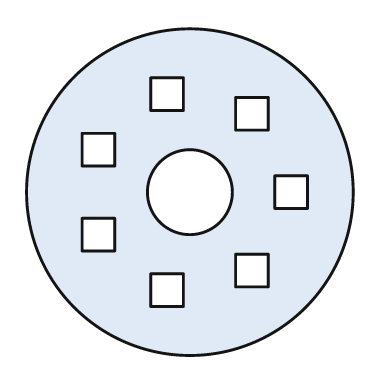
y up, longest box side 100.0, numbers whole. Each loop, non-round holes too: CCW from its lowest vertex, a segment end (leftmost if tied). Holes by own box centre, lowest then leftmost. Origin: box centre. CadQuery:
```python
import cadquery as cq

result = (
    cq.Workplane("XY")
    .moveTo(0.0, 0.0)
    .circle(50.0)
    .moveTo(-12.0, -35.0)
    .lineTo(-2.0, -35.0)
    .lineTo(-2.0, -25.0)
    .lineTo(-12.0, -25.0)
    .close()
    .moveTo(14.0, -29.0)
    .lineTo(24.0, -29.0)
    .lineTo(24.0, -19.0)
    .lineTo(14.0, -19.0)
    .close()
    .moveTo(-33.0, -18.0)
    .lineTo(-23.0, -18.0)
    .lineTo(-23.0, -8.0)
    .lineTo(-33.0, -8.0)
    .close()
    .moveTo(0.0, 0.0)
    .circle(13.0)
    .moveTo(26.0, -5.0)
    .lineTo(36.0, -5.0)
    .lineTo(36.0, 5.0)
    .lineTo(26.0, 5.0)
    .close()
    .moveTo(-33.0, 8.0)
    .lineTo(-23.0, 8.0)
    .lineTo(-23.0, 18.0)
    .lineTo(-33.0, 18.0)
    .close()
    .moveTo(14.0, 19.0)
    .lineTo(24.0, 19.0)
    .lineTo(24.0, 29.0)
    .lineTo(14.0, 29.0)
    .close()
    .moveTo(-12.0, 25.0)
    .lineTo(-2.0, 25.0)
    .lineTo(-2.0, 35.0)
    .lineTo(-12.0, 35.0)
    .close()
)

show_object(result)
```